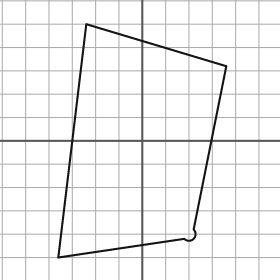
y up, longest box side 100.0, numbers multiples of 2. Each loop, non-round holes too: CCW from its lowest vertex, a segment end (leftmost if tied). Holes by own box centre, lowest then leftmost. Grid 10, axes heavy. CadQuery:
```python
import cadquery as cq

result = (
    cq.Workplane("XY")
    .moveTo(-36.0, -50.0)
    .lineTo(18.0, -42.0)
    .threePointArc((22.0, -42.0), (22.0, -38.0))
    .lineTo(36.0, 32.0)
    .lineTo(-24.0, 50.0)
    .close()
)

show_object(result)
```